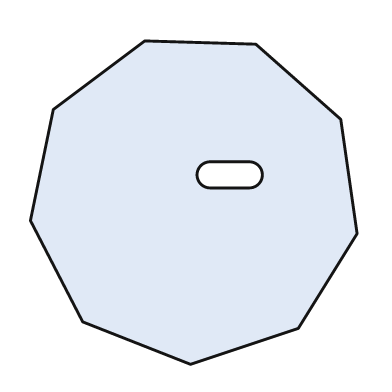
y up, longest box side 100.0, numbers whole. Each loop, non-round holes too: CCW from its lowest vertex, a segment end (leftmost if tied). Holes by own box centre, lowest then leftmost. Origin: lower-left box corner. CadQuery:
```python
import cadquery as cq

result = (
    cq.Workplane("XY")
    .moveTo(49.0, 0.0)
    .lineTo(82.0, 11.0)
    .lineTo(100.0, 40.0)
    .lineTo(95.0, 75.0)
    .lineTo(69.0, 98.0)
    .lineTo(35.0, 99.0)
    .lineTo(7.0, 78.0)
    .lineTo(0.0, 44.0)
    .lineTo(16.0, 13.0)
    .close()
    .moveTo(55.0, 54.0)
    .lineTo(67.0, 54.0)
    .threePointArc((71.0, 58.0), (67.0, 62.0))
    .lineTo(55.0, 62.0)
    .threePointArc((51.0, 58.0), (55.0, 54.0))
    .close()
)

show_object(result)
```